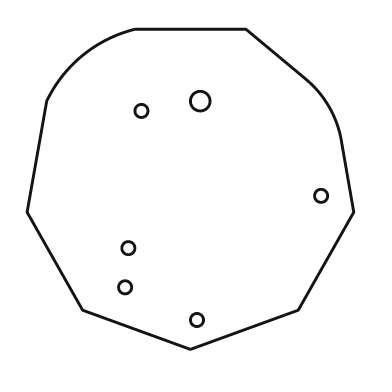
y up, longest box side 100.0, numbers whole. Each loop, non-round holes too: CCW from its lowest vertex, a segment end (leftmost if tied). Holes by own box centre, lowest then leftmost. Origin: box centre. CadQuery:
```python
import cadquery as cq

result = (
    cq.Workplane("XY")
    .moveTo(0.0, -49.0)
    .lineTo(33.0, -37.0)
    .lineTo(50.0, -7.0)
    .lineTo(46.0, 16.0)
    .threePointArc((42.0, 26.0), (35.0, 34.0))
    .lineTo(17.0, 49.0)
    .lineTo(-17.0, 49.0)
    .threePointArc((-33.0, 41.0), (-44.0, 27.0))
    .lineTo(-50.0, -7.0)
    .lineTo(-33.0, -37.0)
    .close()
    .moveTo(2.0, -40.0)
    .circle(2.0)
    .moveTo(-20.0, -30.0)
    .circle(2.0)
    .moveTo(-19.0, -18.0)
    .circle(2.0)
    .moveTo(40.0, -2.0)
    .circle(2.0)
    .moveTo(-15.0, 24.0)
    .circle(2.0)
    .moveTo(3.0, 27.0)
    .circle(3.0)
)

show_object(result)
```